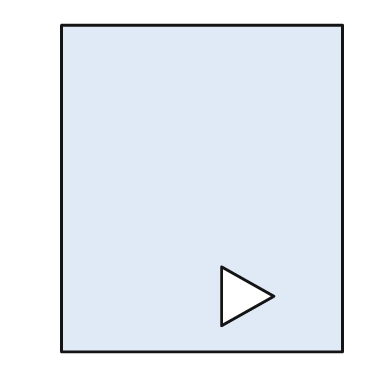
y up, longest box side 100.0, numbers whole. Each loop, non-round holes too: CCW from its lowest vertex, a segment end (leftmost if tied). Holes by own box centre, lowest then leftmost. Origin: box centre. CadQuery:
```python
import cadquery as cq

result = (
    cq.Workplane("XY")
    .moveTo(-43.0, -50.0)
    .lineTo(43.0, -50.0)
    .lineTo(43.0, 50.0)
    .lineTo(-43.0, 50.0)
    .close()
    .moveTo(6.0, -42.0)
    .lineTo(22.0, -33.0)
    .lineTo(6.0, -24.0)
    .close()
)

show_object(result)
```